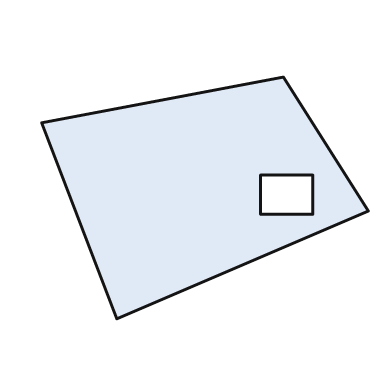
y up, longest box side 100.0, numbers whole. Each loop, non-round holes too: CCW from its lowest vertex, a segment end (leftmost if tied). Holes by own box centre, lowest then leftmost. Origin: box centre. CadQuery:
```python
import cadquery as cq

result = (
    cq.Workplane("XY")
    .moveTo(-27.0, -37.0)
    .lineTo(50.0, -4.0)
    .lineTo(24.0, 37.0)
    .lineTo(-50.0, 23.0)
    .close()
    .moveTo(17.0, -5.0)
    .lineTo(33.0, -5.0)
    .lineTo(33.0, 7.0)
    .lineTo(17.0, 7.0)
    .close()
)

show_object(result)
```